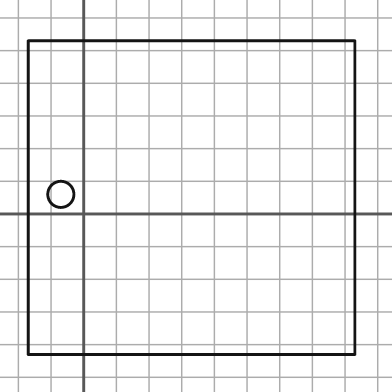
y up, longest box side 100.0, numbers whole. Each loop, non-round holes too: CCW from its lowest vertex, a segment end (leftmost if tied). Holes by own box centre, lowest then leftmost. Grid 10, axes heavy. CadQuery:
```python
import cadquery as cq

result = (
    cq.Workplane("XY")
    .moveTo(-17.0, -43.0)
    .lineTo(83.0, -43.0)
    .lineTo(83.0, 53.0)
    .lineTo(-17.0, 53.0)
    .close()
    .moveTo(-7.0, 6.0)
    .circle(4.0)
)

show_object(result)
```